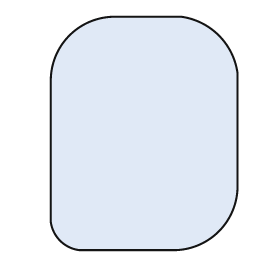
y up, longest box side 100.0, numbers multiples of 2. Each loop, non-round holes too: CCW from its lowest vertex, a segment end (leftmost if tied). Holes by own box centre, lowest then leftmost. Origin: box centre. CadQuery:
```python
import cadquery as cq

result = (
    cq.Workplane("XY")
    .moveTo(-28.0, -50.0)
    .lineTo(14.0, -50.0)
    .threePointArc((32.0, -42.0), (40.0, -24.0))
    .lineTo(40.0, 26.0)
    .threePointArc((32.0, 42.0), (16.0, 50.0))
    .lineTo(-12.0, 50.0)
    .threePointArc((-32.0, 42.0), (-40.0, 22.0))
    .lineTo(-40.0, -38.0)
    .threePointArc((-36.0, -46.0), (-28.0, -50.0))
    .close()
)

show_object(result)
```